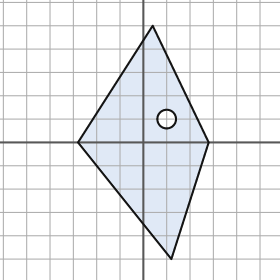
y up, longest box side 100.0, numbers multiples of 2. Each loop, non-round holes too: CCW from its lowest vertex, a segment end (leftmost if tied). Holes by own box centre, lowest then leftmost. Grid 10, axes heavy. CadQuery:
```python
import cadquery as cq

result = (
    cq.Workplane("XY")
    .moveTo(12.0, -50.0)
    .lineTo(28.0, 0.0)
    .lineTo(4.0, 50.0)
    .lineTo(-28.0, 0.0)
    .close()
    .moveTo(10.0, 10.0)
    .circle(4.0)
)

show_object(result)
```